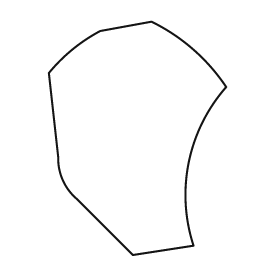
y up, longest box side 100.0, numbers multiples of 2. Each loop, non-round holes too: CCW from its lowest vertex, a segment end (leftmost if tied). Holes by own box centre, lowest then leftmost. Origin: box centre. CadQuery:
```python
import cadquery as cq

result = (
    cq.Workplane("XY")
    .moveTo(-2.0, -50.0)
    .lineTo(24.0, -46.0)
    .threePointArc((22.0, -10.0), (38.0, 22.0))
    .threePointArc((24.0, 38.0), (6.0, 50.0))
    .lineTo(-16.0, 46.0)
    .threePointArc((-28.0, 38.0), (-38.0, 28.0))
    .lineTo(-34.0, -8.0)
    .threePointArc((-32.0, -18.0), (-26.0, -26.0))
    .close()
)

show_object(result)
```